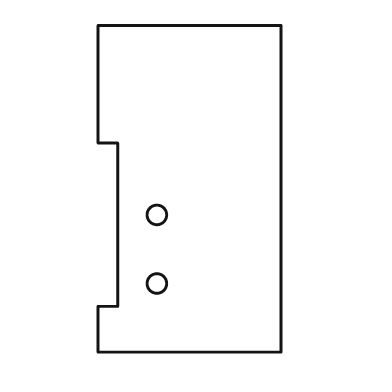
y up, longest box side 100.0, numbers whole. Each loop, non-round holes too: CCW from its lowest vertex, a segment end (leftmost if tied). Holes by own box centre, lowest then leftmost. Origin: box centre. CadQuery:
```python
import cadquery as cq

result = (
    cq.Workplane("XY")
    .moveTo(-28.0, -50.0)
    .lineTo(28.0, -50.0)
    .lineTo(28.0, 50.0)
    .lineTo(-28.0, 50.0)
    .lineTo(-28.0, 14.0)
    .lineTo(-22.0, 14.0)
    .lineTo(-22.0, -36.0)
    .lineTo(-28.0, -36.0)
    .close()
    .moveTo(-10.0, -29.0)
    .circle(3.0)
    .moveTo(-10.0, -8.0)
    .circle(3.0)
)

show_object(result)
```